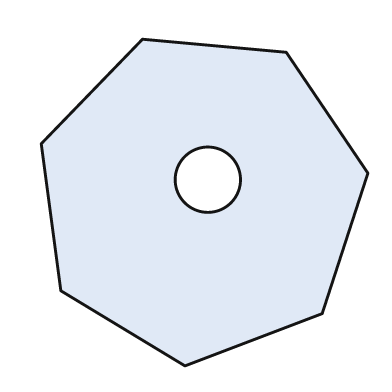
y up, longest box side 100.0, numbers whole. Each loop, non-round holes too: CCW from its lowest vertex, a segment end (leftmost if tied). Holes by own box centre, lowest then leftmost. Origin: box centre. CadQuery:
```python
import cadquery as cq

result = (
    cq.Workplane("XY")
    .moveTo(-6.0, -50.0)
    .lineTo(36.0, -34.0)
    .lineTo(50.0, 9.0)
    .lineTo(25.0, 46.0)
    .lineTo(-19.0, 50.0)
    .lineTo(-50.0, 18.0)
    .lineTo(-44.0, -27.0)
    .close()
    .moveTo(1.0, 7.0)
    .circle(10.0)
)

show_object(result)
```